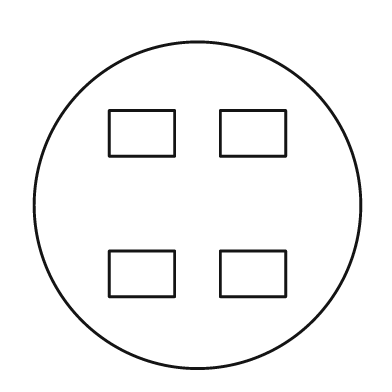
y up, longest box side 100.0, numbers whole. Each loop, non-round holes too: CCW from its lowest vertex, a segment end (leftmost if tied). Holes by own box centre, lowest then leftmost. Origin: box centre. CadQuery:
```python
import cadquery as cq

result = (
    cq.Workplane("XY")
    .moveTo(0.0, 0.0)
    .circle(50.0)
    .moveTo(-27.0, -28.0)
    .lineTo(-7.0, -28.0)
    .lineTo(-7.0, -14.0)
    .lineTo(-27.0, -14.0)
    .close()
    .moveTo(7.0, -28.0)
    .lineTo(27.0, -28.0)
    .lineTo(27.0, -14.0)
    .lineTo(7.0, -14.0)
    .close()
    .moveTo(-27.0, 15.0)
    .lineTo(-7.0, 15.0)
    .lineTo(-7.0, 29.0)
    .lineTo(-27.0, 29.0)
    .close()
    .moveTo(7.0, 15.0)
    .lineTo(27.0, 15.0)
    .lineTo(27.0, 29.0)
    .lineTo(7.0, 29.0)
    .close()
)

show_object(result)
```